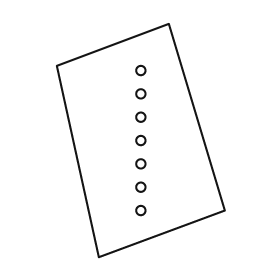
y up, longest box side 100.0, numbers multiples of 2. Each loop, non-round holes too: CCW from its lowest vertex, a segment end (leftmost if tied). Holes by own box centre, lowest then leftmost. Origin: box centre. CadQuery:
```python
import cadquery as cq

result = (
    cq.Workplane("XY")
    .moveTo(-18.0, -50.0)
    .lineTo(36.0, -30.0)
    .lineTo(12.0, 50.0)
    .lineTo(-36.0, 32.0)
    .close()
    .moveTo(0.0, -30.0)
    .circle(2.0)
    .moveTo(0.0, -20.0)
    .circle(2.0)
    .moveTo(0.0, -10.0)
    .circle(2.0)
    .moveTo(0.0, 0.0)
    .circle(2.0)
    .moveTo(0.0, 10.0)
    .circle(2.0)
    .moveTo(0.0, 20.0)
    .circle(2.0)
    .moveTo(0.0, 30.0)
    .circle(2.0)
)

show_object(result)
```